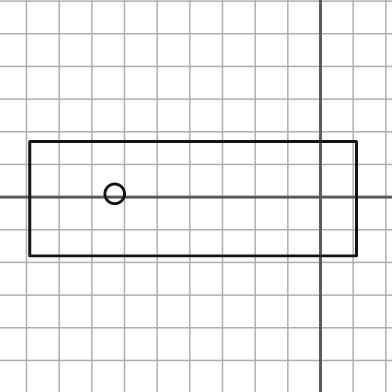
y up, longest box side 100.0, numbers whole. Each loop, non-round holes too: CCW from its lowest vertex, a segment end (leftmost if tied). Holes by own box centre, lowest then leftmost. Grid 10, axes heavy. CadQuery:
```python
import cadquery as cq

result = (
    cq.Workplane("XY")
    .moveTo(-89.0, -18.0)
    .lineTo(11.0, -18.0)
    .lineTo(11.0, 17.0)
    .lineTo(-89.0, 17.0)
    .close()
    .moveTo(-63.0, 1.0)
    .circle(3.0)
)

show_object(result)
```